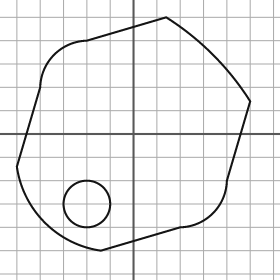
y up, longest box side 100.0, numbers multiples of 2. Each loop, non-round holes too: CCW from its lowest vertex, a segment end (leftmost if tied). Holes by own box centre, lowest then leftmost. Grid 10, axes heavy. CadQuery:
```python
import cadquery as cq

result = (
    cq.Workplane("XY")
    .moveTo(-14.0, -50.0)
    .lineTo(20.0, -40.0)
    .threePointArc((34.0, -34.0), (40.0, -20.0))
    .lineTo(50.0, 14.0)
    .threePointArc((34.0, 34.0), (14.0, 50.0))
    .lineTo(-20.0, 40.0)
    .threePointArc((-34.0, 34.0), (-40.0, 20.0))
    .lineTo(-50.0, -14.0)
    .threePointArc((-38.0, -38.0), (-14.0, -50.0))
    .close()
    .moveTo(-20.0, -30.0)
    .circle(10.0)
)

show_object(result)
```